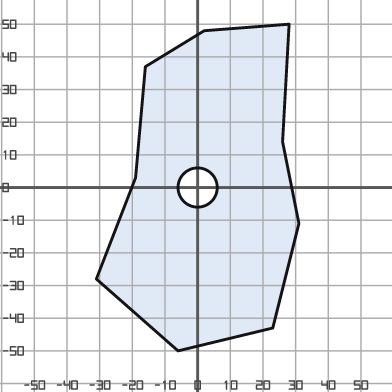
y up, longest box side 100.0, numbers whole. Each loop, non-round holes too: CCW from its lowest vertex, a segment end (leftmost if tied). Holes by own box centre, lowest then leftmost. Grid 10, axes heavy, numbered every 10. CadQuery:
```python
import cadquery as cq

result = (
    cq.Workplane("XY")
    .moveTo(-6.0, -50.0)
    .lineTo(23.0, -43.0)
    .lineTo(31.0, -11.0)
    .lineTo(26.0, 14.0)
    .lineTo(28.0, 50.0)
    .lineTo(2.0, 48.0)
    .lineTo(-16.0, 37.0)
    .lineTo(-19.0, 3.0)
    .lineTo(-31.0, -28.0)
    .close()
    .moveTo(0.0, 0.0)
    .circle(6.0)
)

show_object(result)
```